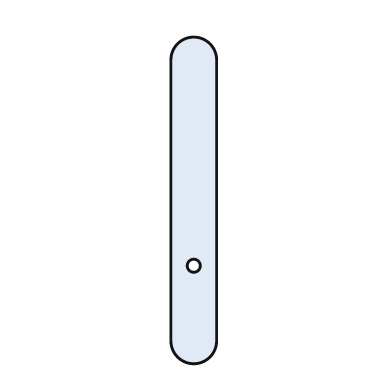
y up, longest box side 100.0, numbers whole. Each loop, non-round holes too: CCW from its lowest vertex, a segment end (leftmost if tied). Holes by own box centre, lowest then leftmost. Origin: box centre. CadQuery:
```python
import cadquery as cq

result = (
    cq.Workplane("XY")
    .moveTo(-7.0, -43.0)
    .threePointArc((0.0, -50.0), (7.0, -43.0))
    .lineTo(7.0, 43.0)
    .threePointArc((0.0, 50.0), (-7.0, 43.0))
    .close()
    .moveTo(0.0, -20.0)
    .circle(2.0)
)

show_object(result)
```